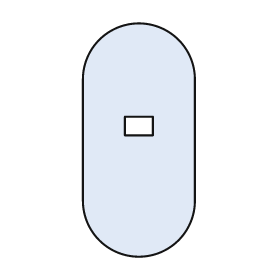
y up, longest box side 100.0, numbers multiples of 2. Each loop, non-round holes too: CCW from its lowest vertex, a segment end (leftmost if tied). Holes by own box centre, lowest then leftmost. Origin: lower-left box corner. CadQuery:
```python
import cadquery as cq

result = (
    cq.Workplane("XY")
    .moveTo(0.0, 24.0)
    .threePointArc((24.0, 0.0), (48.0, 24.0))
    .lineTo(48.0, 76.0)
    .threePointArc((24.0, 100.0), (0.0, 76.0))
    .close()
    .moveTo(18.0, 52.0)
    .lineTo(30.0, 52.0)
    .lineTo(30.0, 60.0)
    .lineTo(18.0, 60.0)
    .close()
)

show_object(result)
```